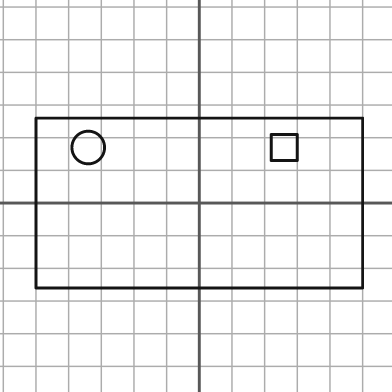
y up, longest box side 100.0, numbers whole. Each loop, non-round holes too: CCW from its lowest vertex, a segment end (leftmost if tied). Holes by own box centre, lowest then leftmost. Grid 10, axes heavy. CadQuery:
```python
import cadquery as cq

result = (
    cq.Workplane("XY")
    .moveTo(-50.0, -26.0)
    .lineTo(50.0, -26.0)
    .lineTo(50.0, 26.0)
    .lineTo(-50.0, 26.0)
    .close()
    .moveTo(-34.0, 17.0)
    .circle(5.0)
    .moveTo(22.0, 13.0)
    .lineTo(30.0, 13.0)
    .lineTo(30.0, 21.0)
    .lineTo(22.0, 21.0)
    .close()
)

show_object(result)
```